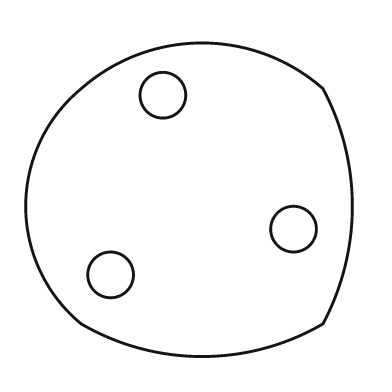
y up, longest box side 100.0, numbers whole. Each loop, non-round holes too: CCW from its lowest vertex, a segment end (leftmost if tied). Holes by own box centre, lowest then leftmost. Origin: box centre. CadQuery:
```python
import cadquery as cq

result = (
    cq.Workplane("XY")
    .moveTo(-33.0, -38.0)
    .threePointArc((4.0, -48.0), (41.0, -38.0))
    .threePointArc((50.0, -2.0), (41.0, 34.0))
    .threePointArc((4.0, 48.0), (-33.0, 34.0))
    .threePointArc((-50.0, -2.0), (-33.0, -38.0))
    .close()
    .moveTo(-24.0, -23.0)
    .circle(7.0)
    .moveTo(32.0, -9.0)
    .circle(7.0)
    .moveTo(-8.0, 32.0)
    .circle(7.0)
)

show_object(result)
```